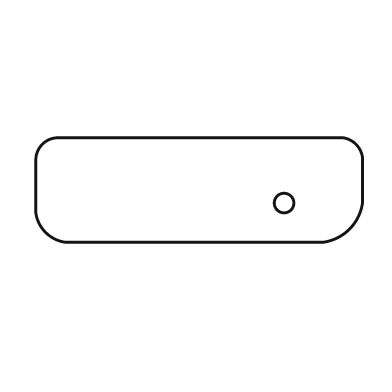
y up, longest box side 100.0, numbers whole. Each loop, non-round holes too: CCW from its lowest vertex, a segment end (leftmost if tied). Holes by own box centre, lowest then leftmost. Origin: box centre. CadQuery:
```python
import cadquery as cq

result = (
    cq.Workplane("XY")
    .moveTo(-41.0, -16.0)
    .lineTo(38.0, -16.0)
    .threePointArc((46.0, -12.0), (50.0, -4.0))
    .lineTo(50.0, 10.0)
    .threePointArc((48.0, 14.0), (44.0, 16.0))
    .lineTo(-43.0, 16.0)
    .threePointArc((-48.0, 14.0), (-50.0, 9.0))
    .lineTo(-50.0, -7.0)
    .threePointArc((-47.0, -13.0), (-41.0, -16.0))
    .close()
    .moveTo(26.0, -4.0)
    .circle(3.0)
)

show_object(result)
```